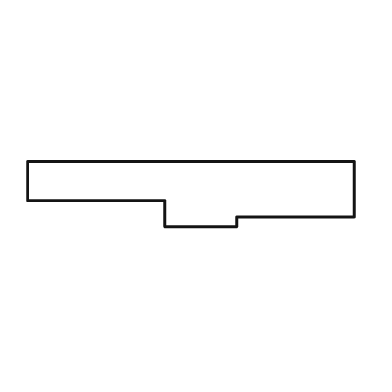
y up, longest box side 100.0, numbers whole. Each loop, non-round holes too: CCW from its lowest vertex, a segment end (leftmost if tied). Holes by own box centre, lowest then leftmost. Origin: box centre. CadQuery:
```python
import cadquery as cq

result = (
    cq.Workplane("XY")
    .moveTo(-8.0, -10.0)
    .lineTo(14.0, -10.0)
    .lineTo(14.0, -7.0)
    .lineTo(50.0, -7.0)
    .lineTo(50.0, 10.0)
    .lineTo(-50.0, 10.0)
    .lineTo(-50.0, -2.0)
    .lineTo(-8.0, -2.0)
    .close()
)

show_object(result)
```